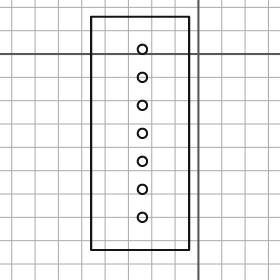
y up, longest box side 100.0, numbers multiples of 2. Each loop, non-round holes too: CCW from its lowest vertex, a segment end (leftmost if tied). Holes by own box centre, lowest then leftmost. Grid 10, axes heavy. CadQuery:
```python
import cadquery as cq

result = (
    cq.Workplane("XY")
    .moveTo(-46.0, -84.0)
    .lineTo(-4.0, -84.0)
    .lineTo(-4.0, 16.0)
    .lineTo(-46.0, 16.0)
    .close()
    .moveTo(-24.0, -70.0)
    .circle(2.0)
    .moveTo(-24.0, -58.0)
    .circle(2.0)
    .moveTo(-24.0, -46.0)
    .circle(2.0)
    .moveTo(-24.0, -34.0)
    .circle(2.0)
    .moveTo(-24.0, -22.0)
    .circle(2.0)
    .moveTo(-24.0, -10.0)
    .circle(2.0)
    .moveTo(-24.0, 2.0)
    .circle(2.0)
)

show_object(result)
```